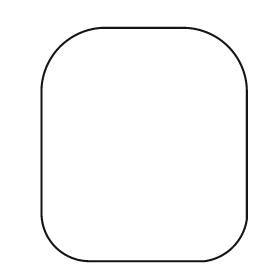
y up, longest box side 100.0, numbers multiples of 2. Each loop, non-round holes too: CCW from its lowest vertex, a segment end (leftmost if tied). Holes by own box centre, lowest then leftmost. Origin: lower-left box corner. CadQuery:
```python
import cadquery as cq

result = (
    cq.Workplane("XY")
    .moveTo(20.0, 0.0)
    .lineTo(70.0, 0.0)
    .threePointArc((82.0, 6.0), (88.0, 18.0))
    .lineTo(88.0, 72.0)
    .threePointArc((80.0, 92.0), (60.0, 100.0))
    .lineTo(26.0, 100.0)
    .threePointArc((8.0, 92.0), (0.0, 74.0))
    .lineTo(0.0, 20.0)
    .threePointArc((6.0, 6.0), (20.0, 0.0))
    .close()
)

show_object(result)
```